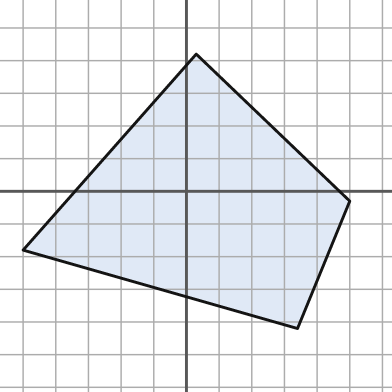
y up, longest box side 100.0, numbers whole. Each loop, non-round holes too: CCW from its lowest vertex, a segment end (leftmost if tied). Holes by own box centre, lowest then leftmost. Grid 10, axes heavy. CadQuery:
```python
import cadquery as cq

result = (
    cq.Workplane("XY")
    .moveTo(34.0, -42.0)
    .lineTo(50.0, -3.0)
    .lineTo(3.0, 42.0)
    .lineTo(-50.0, -18.0)
    .close()
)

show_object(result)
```